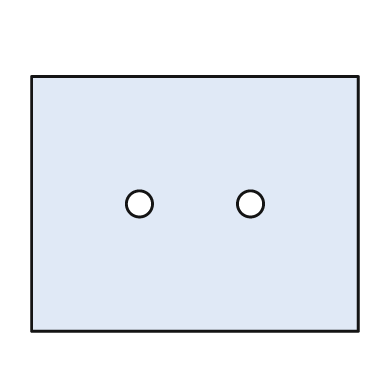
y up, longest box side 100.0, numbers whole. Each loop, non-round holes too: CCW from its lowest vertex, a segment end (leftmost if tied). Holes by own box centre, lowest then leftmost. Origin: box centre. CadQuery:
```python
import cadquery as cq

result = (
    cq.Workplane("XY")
    .moveTo(-50.0, -39.0)
    .lineTo(50.0, -39.0)
    .lineTo(50.0, 39.0)
    .lineTo(-50.0, 39.0)
    .close()
    .moveTo(-17.0, 0.0)
    .circle(4.0)
    .moveTo(17.0, 0.0)
    .circle(4.0)
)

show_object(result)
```